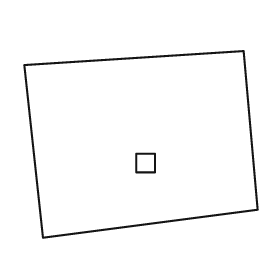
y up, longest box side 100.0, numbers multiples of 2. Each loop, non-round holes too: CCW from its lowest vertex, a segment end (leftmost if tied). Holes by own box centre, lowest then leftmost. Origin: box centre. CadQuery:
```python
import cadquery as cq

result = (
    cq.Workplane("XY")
    .moveTo(-42.0, -40.0)
    .lineTo(50.0, -28.0)
    .lineTo(44.0, 40.0)
    .lineTo(-50.0, 34.0)
    .close()
    .moveTo(-2.0, -12.0)
    .lineTo(6.0, -12.0)
    .lineTo(6.0, -4.0)
    .lineTo(-2.0, -4.0)
    .close()
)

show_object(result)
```